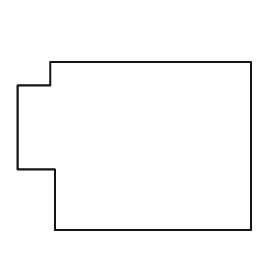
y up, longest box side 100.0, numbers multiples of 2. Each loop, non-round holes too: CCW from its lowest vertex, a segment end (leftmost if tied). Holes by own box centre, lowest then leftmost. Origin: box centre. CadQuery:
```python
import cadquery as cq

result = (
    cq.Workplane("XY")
    .moveTo(-34.0, -36.0)
    .lineTo(50.0, -36.0)
    .lineTo(50.0, 36.0)
    .lineTo(-36.0, 36.0)
    .lineTo(-36.0, 26.0)
    .lineTo(-50.0, 26.0)
    .lineTo(-50.0, -10.0)
    .lineTo(-34.0, -10.0)
    .close()
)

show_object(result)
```